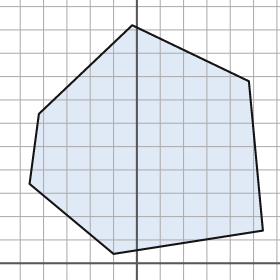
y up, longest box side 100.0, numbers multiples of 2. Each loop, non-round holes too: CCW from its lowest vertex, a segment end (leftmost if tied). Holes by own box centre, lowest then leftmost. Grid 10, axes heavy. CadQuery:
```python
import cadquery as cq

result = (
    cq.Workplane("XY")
    .moveTo(-10.0, 4.0)
    .lineTo(54.0, 14.0)
    .lineTo(48.0, 78.0)
    .lineTo(-2.0, 102.0)
    .lineTo(-42.0, 64.0)
    .lineTo(-46.0, 34.0)
    .close()
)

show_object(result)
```